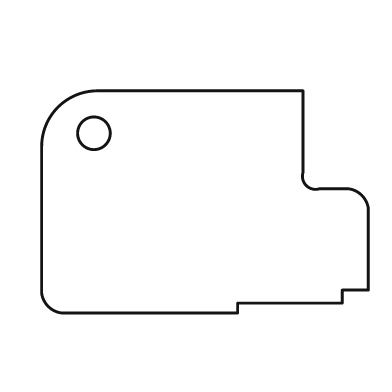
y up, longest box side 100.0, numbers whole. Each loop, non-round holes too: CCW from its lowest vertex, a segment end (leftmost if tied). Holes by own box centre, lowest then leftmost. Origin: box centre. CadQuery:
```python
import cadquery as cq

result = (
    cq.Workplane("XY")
    .moveTo(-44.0, -34.0)
    .lineTo(10.0, -34.0)
    .lineTo(10.0, -31.0)
    .lineTo(42.0, -31.0)
    .lineTo(42.0, -27.0)
    .lineTo(50.0, -27.0)
    .lineTo(50.0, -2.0)
    .threePointArc((48.0, 2.0), (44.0, 4.0))
    .lineTo(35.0, 4.0)
    .threePointArc((31.0, 5.0), (30.0, 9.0))
    .lineTo(30.0, 34.0)
    .lineTo(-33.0, 34.0)
    .threePointArc((-45.0, 29.0), (-50.0, 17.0))
    .lineTo(-50.0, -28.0)
    .threePointArc((-48.0, -32.0), (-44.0, -34.0))
    .close()
    .moveTo(-34.0, 21.0)
    .circle(5.0)
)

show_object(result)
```